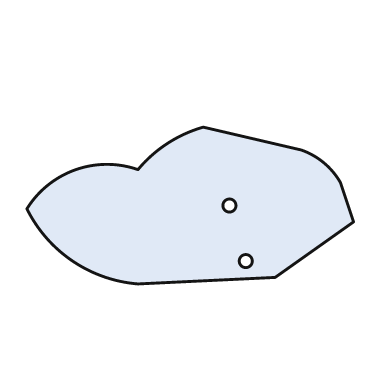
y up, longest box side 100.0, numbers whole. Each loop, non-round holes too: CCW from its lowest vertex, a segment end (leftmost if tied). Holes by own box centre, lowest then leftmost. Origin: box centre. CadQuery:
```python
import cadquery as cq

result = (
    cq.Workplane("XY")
    .moveTo(-16.0, -24.0)
    .lineTo(26.0, -22.0)
    .lineTo(50.0, -5.0)
    .lineTo(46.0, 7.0)
    .threePointArc((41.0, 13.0), (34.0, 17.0))
    .lineTo(4.0, 24.0)
    .threePointArc((-7.0, 19.0), (-16.0, 11.0))
    .threePointArc((-35.0, 11.0), (-50.0, -1.0))
    .threePointArc((-36.0, -17.0), (-16.0, -24.0))
    .close()
    .moveTo(17.0, -17.0)
    .circle(2.0)
    .moveTo(12.0, 0.0)
    .circle(2.0)
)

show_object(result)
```